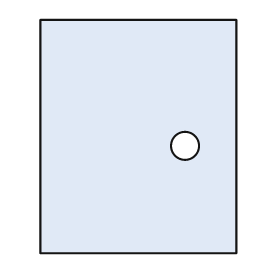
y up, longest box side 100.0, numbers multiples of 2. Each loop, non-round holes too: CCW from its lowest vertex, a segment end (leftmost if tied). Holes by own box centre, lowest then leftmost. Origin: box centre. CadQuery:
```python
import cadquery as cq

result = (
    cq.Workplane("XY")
    .moveTo(-42.0, -50.0)
    .lineTo(42.0, -50.0)
    .lineTo(42.0, 50.0)
    .lineTo(-42.0, 50.0)
    .close()
    .moveTo(20.0, -4.0)
    .circle(6.0)
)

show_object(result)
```